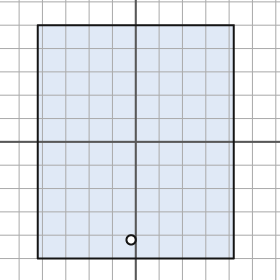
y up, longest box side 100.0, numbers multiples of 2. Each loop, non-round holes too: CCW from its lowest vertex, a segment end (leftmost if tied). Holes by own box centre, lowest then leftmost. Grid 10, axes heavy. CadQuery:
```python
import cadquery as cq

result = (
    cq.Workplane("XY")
    .moveTo(-42.0, -50.0)
    .lineTo(42.0, -50.0)
    .lineTo(42.0, 50.0)
    .lineTo(-42.0, 50.0)
    .close()
    .moveTo(-2.0, -42.0)
    .circle(2.0)
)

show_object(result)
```